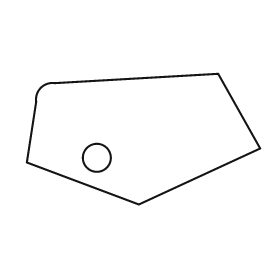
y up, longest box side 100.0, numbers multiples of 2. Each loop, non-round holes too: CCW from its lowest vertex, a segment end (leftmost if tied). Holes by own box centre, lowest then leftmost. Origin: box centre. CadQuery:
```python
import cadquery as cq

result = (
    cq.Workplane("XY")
    .moveTo(-2.0, -28.0)
    .lineTo(50.0, -4.0)
    .lineTo(32.0, 28.0)
    .lineTo(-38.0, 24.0)
    .threePointArc((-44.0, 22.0), (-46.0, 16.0))
    .lineTo(-50.0, -10.0)
    .close()
    .moveTo(-20.0, -8.0)
    .circle(6.0)
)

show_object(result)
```